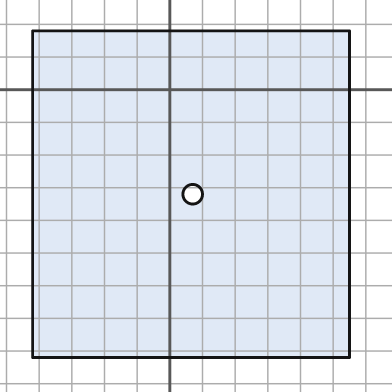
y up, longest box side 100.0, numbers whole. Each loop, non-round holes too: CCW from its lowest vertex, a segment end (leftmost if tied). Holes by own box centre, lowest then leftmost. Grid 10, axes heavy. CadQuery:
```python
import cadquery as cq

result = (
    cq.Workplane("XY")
    .moveTo(-42.0, -82.0)
    .lineTo(55.0, -82.0)
    .lineTo(55.0, 18.0)
    .lineTo(-42.0, 18.0)
    .close()
    .moveTo(7.0, -32.0)
    .circle(3.0)
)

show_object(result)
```